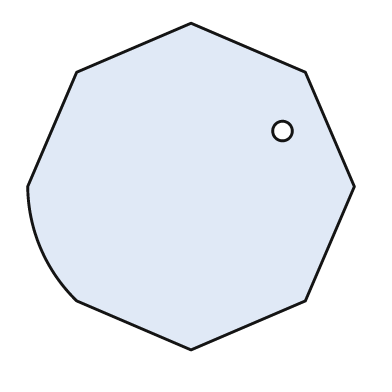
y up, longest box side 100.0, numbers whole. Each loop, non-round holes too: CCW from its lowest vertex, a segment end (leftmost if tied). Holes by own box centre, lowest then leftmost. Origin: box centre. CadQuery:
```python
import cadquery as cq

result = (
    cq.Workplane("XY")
    .moveTo(0.0, -50.0)
    .lineTo(35.0, -35.0)
    .lineTo(50.0, 0.0)
    .lineTo(35.0, 35.0)
    .lineTo(0.0, 50.0)
    .lineTo(-35.0, 35.0)
    .lineTo(-50.0, 0.0)
    .threePointArc((-46.0, -19.0), (-35.0, -35.0))
    .close()
    .moveTo(28.0, 17.0)
    .circle(3.0)
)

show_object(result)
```